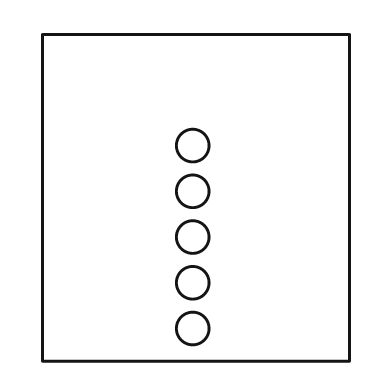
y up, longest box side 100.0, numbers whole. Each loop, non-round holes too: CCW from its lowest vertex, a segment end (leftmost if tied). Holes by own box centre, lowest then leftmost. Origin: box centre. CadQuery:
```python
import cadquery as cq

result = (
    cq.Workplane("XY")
    .moveTo(-47.0, -50.0)
    .lineTo(47.0, -50.0)
    .lineTo(47.0, 50.0)
    .lineTo(-47.0, 50.0)
    .close()
    .moveTo(-1.0, -40.0)
    .circle(5.0)
    .moveTo(-1.0, -26.0)
    .circle(5.0)
    .moveTo(-1.0, -12.0)
    .circle(5.0)
    .moveTo(-1.0, 2.0)
    .circle(5.0)
    .moveTo(-1.0, 16.0)
    .circle(5.0)
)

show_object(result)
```